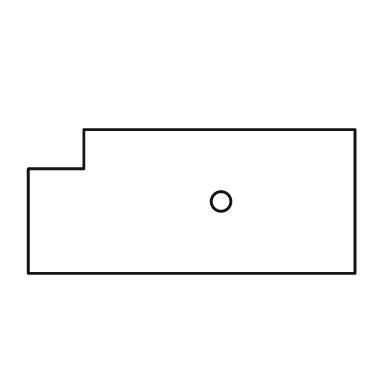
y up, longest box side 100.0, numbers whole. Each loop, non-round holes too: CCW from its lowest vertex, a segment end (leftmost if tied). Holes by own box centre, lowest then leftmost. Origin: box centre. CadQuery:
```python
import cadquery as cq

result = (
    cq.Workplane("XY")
    .moveTo(-50.0, -22.0)
    .lineTo(50.0, -22.0)
    .lineTo(50.0, 22.0)
    .lineTo(-33.0, 22.0)
    .lineTo(-33.0, 10.0)
    .lineTo(-50.0, 10.0)
    .close()
    .moveTo(9.0, 0.0)
    .circle(3.0)
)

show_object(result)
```